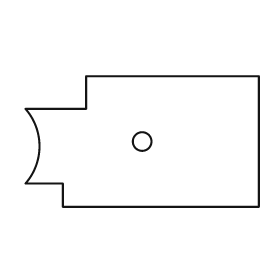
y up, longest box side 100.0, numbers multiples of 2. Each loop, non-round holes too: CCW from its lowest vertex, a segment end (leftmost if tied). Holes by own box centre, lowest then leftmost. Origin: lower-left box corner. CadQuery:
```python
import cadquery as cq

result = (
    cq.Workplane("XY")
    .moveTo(16.0, 0.0)
    .lineTo(100.0, 0.0)
    .lineTo(100.0, 56.0)
    .lineTo(26.0, 56.0)
    .lineTo(26.0, 42.0)
    .lineTo(0.0, 42.0)
    .threePointArc((6.0, 26.0), (0.0, 10.0))
    .lineTo(16.0, 10.0)
    .close()
    .moveTo(50.0, 28.0)
    .circle(4.0)
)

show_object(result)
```